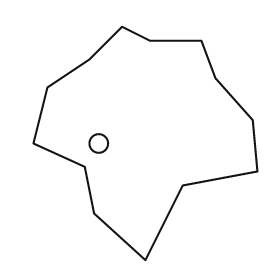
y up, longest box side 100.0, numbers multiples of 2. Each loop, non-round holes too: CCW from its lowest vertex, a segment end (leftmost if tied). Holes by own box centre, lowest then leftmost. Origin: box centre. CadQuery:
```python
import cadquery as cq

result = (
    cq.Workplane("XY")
    .moveTo(0.0, -50.0)
    .lineTo(16.0, -18.0)
    .lineTo(48.0, -12.0)
    .lineTo(46.0, 10.0)
    .lineTo(30.0, 28.0)
    .lineTo(24.0, 44.0)
    .lineTo(2.0, 44.0)
    .lineTo(-10.0, 50.0)
    .lineTo(-24.0, 36.0)
    .lineTo(-42.0, 24.0)
    .lineTo(-48.0, 0.0)
    .lineTo(-26.0, -10.0)
    .lineTo(-22.0, -30.0)
    .close()
    .moveTo(-20.0, 0.0)
    .circle(4.0)
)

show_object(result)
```